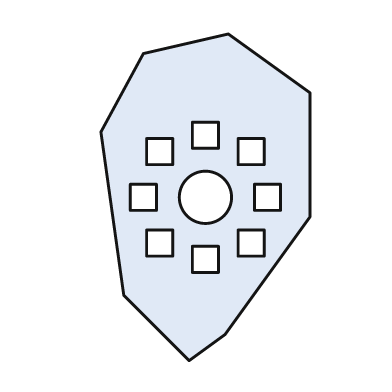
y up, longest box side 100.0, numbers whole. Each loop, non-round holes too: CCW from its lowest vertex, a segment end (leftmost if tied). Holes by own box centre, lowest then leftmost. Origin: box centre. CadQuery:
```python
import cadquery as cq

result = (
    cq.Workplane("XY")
    .moveTo(-5.0, -50.0)
    .lineTo(6.0, -42.0)
    .lineTo(32.0, -6.0)
    .lineTo(32.0, 32.0)
    .lineTo(7.0, 50.0)
    .lineTo(-19.0, 44.0)
    .lineTo(-32.0, 20.0)
    .lineTo(-25.0, -30.0)
    .close()
    .moveTo(-4.0, -23.0)
    .lineTo(4.0, -23.0)
    .lineTo(4.0, -15.0)
    .lineTo(-4.0, -15.0)
    .close()
    .moveTo(-18.0, -18.0)
    .lineTo(-10.0, -18.0)
    .lineTo(-10.0, -10.0)
    .lineTo(-18.0, -10.0)
    .close()
    .moveTo(10.0, -18.0)
    .lineTo(18.0, -18.0)
    .lineTo(18.0, -10.0)
    .lineTo(10.0, -10.0)
    .close()
    .moveTo(-23.0, -4.0)
    .lineTo(-15.0, -4.0)
    .lineTo(-15.0, 4.0)
    .lineTo(-23.0, 4.0)
    .close()
    .moveTo(0.0, 0.0)
    .circle(8.0)
    .moveTo(15.0, -4.0)
    .lineTo(23.0, -4.0)
    .lineTo(23.0, 4.0)
    .lineTo(15.0, 4.0)
    .close()
    .moveTo(-18.0, 10.0)
    .lineTo(-10.0, 10.0)
    .lineTo(-10.0, 18.0)
    .lineTo(-18.0, 18.0)
    .close()
    .moveTo(10.0, 10.0)
    .lineTo(18.0, 10.0)
    .lineTo(18.0, 18.0)
    .lineTo(10.0, 18.0)
    .close()
    .moveTo(-4.0, 15.0)
    .lineTo(4.0, 15.0)
    .lineTo(4.0, 23.0)
    .lineTo(-4.0, 23.0)
    .close()
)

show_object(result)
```